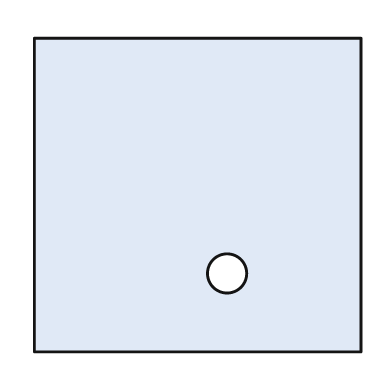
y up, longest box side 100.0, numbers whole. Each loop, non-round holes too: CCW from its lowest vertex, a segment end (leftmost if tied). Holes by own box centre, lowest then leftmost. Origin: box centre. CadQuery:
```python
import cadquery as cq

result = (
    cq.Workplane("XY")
    .moveTo(-50.0, -48.0)
    .lineTo(50.0, -48.0)
    .lineTo(50.0, 48.0)
    .lineTo(-50.0, 48.0)
    .close()
    .moveTo(9.0, -24.0)
    .circle(6.0)
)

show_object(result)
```